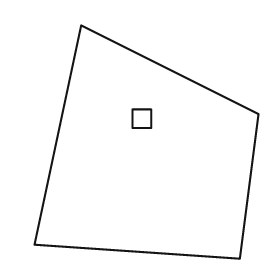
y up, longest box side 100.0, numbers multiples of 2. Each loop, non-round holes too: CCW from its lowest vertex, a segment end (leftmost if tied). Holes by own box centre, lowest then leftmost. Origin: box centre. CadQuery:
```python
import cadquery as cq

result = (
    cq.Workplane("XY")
    .moveTo(40.0, -50.0)
    .lineTo(48.0, 12.0)
    .lineTo(-28.0, 50.0)
    .lineTo(-48.0, -44.0)
    .close()
    .moveTo(-6.0, 6.0)
    .lineTo(2.0, 6.0)
    .lineTo(2.0, 14.0)
    .lineTo(-6.0, 14.0)
    .close()
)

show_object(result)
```